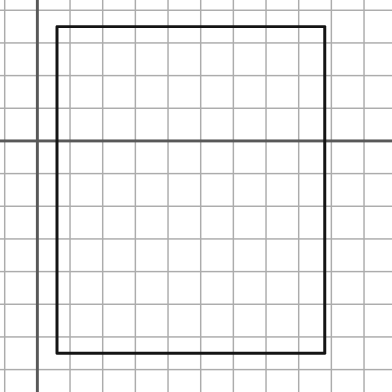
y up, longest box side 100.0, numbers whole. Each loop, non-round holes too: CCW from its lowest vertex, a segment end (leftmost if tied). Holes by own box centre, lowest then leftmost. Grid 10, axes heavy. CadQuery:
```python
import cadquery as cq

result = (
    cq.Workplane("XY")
    .moveTo(6.0, -65.0)
    .lineTo(88.0, -65.0)
    .lineTo(88.0, 35.0)
    .lineTo(6.0, 35.0)
    .close()
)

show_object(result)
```